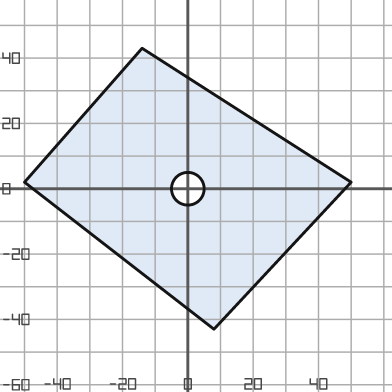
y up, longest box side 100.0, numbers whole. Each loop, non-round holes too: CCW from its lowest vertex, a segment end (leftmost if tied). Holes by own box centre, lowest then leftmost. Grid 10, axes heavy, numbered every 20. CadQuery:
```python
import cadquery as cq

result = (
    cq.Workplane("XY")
    .moveTo(8.0, -43.0)
    .lineTo(50.0, 2.0)
    .lineTo(-14.0, 43.0)
    .lineTo(-50.0, 2.0)
    .close()
    .moveTo(0.0, 0.0)
    .circle(5.0)
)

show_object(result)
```